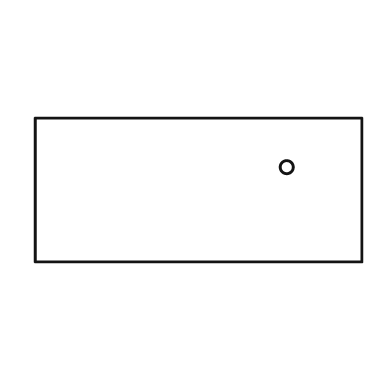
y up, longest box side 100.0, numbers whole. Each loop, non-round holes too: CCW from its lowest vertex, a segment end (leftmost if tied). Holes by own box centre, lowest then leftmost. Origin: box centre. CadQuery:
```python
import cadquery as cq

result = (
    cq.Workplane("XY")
    .moveTo(-50.0, -22.0)
    .lineTo(50.0, -22.0)
    .lineTo(50.0, 22.0)
    .lineTo(-50.0, 22.0)
    .close()
    .moveTo(27.0, 7.0)
    .circle(2.0)
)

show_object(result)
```